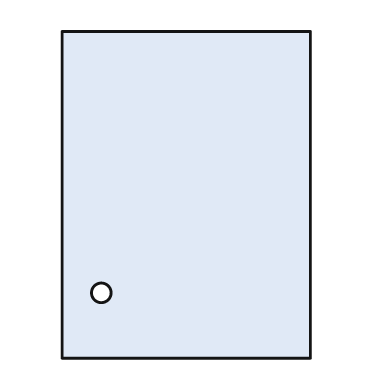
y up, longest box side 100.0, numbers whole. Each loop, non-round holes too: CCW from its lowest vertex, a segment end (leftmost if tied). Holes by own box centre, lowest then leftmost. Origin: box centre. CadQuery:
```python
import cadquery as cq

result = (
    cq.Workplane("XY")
    .moveTo(-38.0, -50.0)
    .lineTo(38.0, -50.0)
    .lineTo(38.0, 50.0)
    .lineTo(-38.0, 50.0)
    .close()
    .moveTo(-26.0, -30.0)
    .circle(3.0)
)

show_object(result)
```